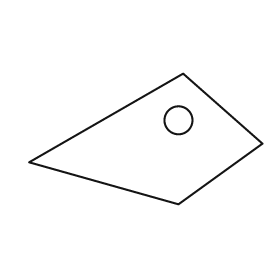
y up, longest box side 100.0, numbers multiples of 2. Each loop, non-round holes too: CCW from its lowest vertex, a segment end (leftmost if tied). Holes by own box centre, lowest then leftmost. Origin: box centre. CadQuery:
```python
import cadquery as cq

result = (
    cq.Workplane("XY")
    .moveTo(14.0, -28.0)
    .lineTo(50.0, -2.0)
    .lineTo(16.0, 28.0)
    .lineTo(-50.0, -10.0)
    .close()
    .moveTo(14.0, 8.0)
    .circle(6.0)
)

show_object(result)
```